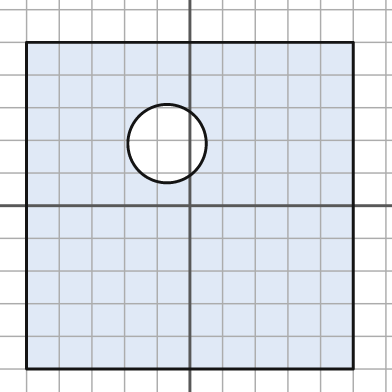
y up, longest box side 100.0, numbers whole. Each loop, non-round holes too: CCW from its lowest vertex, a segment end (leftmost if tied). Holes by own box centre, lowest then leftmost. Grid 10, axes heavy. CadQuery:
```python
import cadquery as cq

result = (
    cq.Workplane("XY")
    .moveTo(-50.0, -50.0)
    .lineTo(50.0, -50.0)
    .lineTo(50.0, 50.0)
    .lineTo(-50.0, 50.0)
    .close()
    .moveTo(-7.0, 19.0)
    .circle(12.0)
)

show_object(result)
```